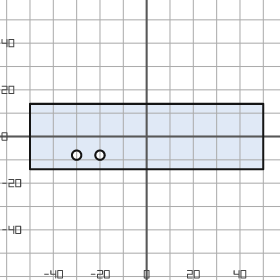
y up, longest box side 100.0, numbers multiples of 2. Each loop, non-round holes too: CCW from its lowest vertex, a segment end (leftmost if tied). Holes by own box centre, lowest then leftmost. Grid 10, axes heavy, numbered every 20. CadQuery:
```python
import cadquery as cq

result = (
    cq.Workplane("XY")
    .moveTo(-50.0, -14.0)
    .lineTo(50.0, -14.0)
    .lineTo(50.0, 14.0)
    .lineTo(-50.0, 14.0)
    .close()
    .moveTo(-30.0, -8.0)
    .circle(2.0)
    .moveTo(-20.0, -8.0)
    .circle(2.0)
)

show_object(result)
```